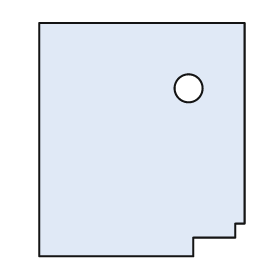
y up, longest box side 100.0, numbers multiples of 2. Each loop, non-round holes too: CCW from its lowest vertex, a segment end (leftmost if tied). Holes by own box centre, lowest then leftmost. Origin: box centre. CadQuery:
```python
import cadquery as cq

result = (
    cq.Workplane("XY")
    .moveTo(-44.0, -50.0)
    .lineTo(22.0, -50.0)
    .lineTo(22.0, -42.0)
    .lineTo(40.0, -42.0)
    .lineTo(40.0, -36.0)
    .lineTo(44.0, -36.0)
    .lineTo(44.0, 50.0)
    .lineTo(-44.0, 50.0)
    .close()
    .moveTo(20.0, 22.0)
    .circle(6.0)
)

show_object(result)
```